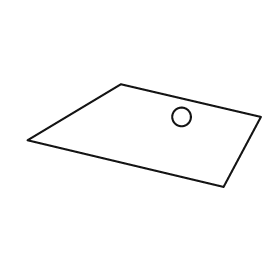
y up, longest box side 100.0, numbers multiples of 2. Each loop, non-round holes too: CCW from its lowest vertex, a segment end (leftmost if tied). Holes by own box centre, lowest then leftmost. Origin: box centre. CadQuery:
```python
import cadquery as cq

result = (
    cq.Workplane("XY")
    .moveTo(34.0, -22.0)
    .lineTo(50.0, 8.0)
    .lineTo(-10.0, 22.0)
    .lineTo(-50.0, -2.0)
    .close()
    .moveTo(16.0, 8.0)
    .circle(4.0)
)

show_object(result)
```